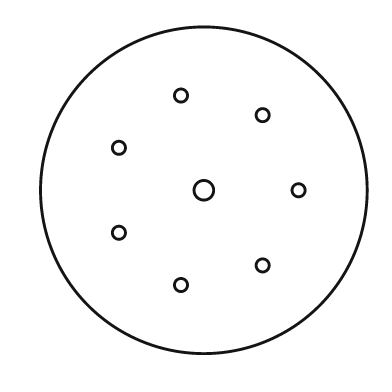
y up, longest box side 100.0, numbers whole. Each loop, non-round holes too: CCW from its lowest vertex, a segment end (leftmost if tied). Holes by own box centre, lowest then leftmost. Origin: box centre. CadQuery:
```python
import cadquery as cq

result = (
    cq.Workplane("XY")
    .moveTo(0.0, 0.0)
    .circle(50.0)
    .moveTo(-7.0, -29.0)
    .circle(2.0)
    .moveTo(18.0, -23.0)
    .circle(2.0)
    .moveTo(-26.0, -13.0)
    .circle(2.0)
    .moveTo(0.0, 0.0)
    .circle(3.0)
    .moveTo(29.0, 0.0)
    .circle(2.0)
    .moveTo(-26.0, 13.0)
    .circle(2.0)
    .moveTo(18.0, 23.0)
    .circle(2.0)
    .moveTo(-7.0, 29.0)
    .circle(2.0)
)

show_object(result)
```